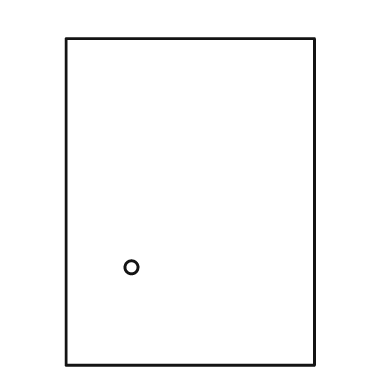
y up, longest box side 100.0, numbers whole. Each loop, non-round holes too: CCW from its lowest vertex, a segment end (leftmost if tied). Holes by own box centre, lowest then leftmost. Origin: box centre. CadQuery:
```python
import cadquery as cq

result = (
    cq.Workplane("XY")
    .moveTo(-38.0, -50.0)
    .lineTo(38.0, -50.0)
    .lineTo(38.0, 50.0)
    .lineTo(-38.0, 50.0)
    .close()
    .moveTo(-18.0, -20.0)
    .circle(2.0)
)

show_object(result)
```